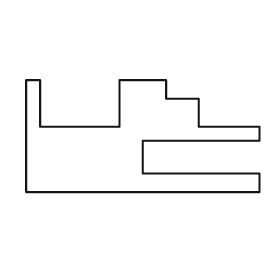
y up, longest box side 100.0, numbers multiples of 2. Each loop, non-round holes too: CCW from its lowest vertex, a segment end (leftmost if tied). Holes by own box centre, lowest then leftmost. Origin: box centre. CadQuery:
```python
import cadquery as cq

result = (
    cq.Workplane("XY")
    .moveTo(-50.0, -24.0)
    .lineTo(50.0, -24.0)
    .lineTo(50.0, -16.0)
    .lineTo(0.0, -16.0)
    .lineTo(0.0, -2.0)
    .lineTo(50.0, -2.0)
    .lineTo(50.0, 4.0)
    .lineTo(24.0, 4.0)
    .lineTo(24.0, 16.0)
    .lineTo(10.0, 16.0)
    .lineTo(10.0, 24.0)
    .lineTo(-10.0, 24.0)
    .lineTo(-10.0, 4.0)
    .lineTo(-44.0, 4.0)
    .lineTo(-44.0, 24.0)
    .lineTo(-50.0, 24.0)
    .close()
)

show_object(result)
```